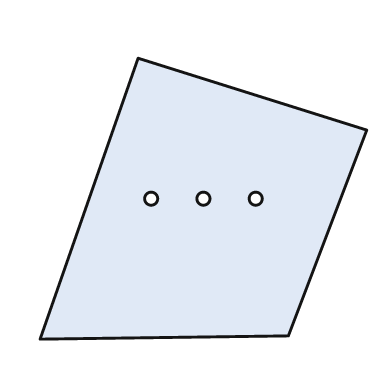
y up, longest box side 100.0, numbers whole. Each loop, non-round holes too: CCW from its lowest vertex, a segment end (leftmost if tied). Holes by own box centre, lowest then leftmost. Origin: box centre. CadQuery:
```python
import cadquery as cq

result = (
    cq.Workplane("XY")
    .moveTo(-50.0, -43.0)
    .lineTo(26.0, -42.0)
    .lineTo(50.0, 21.0)
    .lineTo(-20.0, 43.0)
    .close()
    .moveTo(-16.0, 0.0)
    .circle(2.0)
    .moveTo(0.0, 0.0)
    .circle(2.0)
    .moveTo(16.0, 0.0)
    .circle(2.0)
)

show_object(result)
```